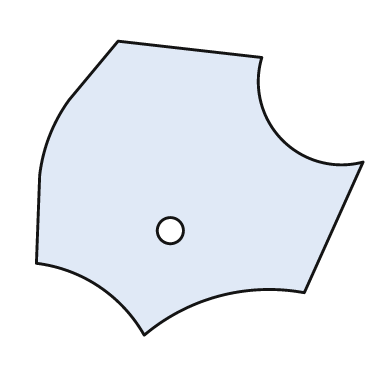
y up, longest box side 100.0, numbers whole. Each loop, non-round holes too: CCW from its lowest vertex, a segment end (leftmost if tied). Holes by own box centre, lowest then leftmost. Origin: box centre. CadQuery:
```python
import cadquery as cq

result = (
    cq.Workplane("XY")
    .moveTo(-17.0, -45.0)
    .threePointArc((6.0, -33.0), (32.0, -32.0))
    .lineTo(50.0, 8.0)
    .threePointArc((25.0, 15.0), (19.0, 40.0))
    .lineTo(-25.0, 45.0)
    .lineTo(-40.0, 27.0)
    .threePointArc((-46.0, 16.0), (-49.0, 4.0))
    .lineTo(-50.0, -23.0)
    .threePointArc((-31.0, -30.0), (-17.0, -45.0))
    .close()
    .moveTo(-9.0, -13.0)
    .circle(4.0)
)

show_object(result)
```